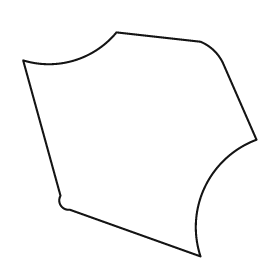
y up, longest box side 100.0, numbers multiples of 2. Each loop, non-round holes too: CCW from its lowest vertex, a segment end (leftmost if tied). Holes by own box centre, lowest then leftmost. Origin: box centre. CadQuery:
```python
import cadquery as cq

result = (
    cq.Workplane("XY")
    .moveTo(26.0, -48.0)
    .threePointArc((28.0, -18.0), (50.0, 2.0))
    .lineTo(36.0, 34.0)
    .threePointArc((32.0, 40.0), (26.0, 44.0))
    .lineTo(-10.0, 48.0)
    .threePointArc((-28.0, 36.0), (-50.0, 36.0))
    .lineTo(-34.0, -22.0)
    .threePointArc((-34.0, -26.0), (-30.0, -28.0))
    .close()
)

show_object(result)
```